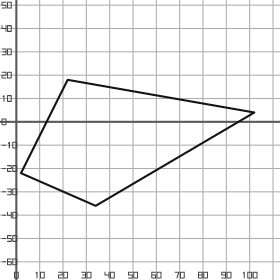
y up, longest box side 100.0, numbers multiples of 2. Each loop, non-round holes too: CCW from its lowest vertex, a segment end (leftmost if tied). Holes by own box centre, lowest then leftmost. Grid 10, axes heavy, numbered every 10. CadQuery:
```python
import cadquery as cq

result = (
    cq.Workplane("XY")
    .moveTo(34.0, -36.0)
    .lineTo(102.0, 4.0)
    .lineTo(22.0, 18.0)
    .lineTo(2.0, -22.0)
    .close()
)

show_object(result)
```